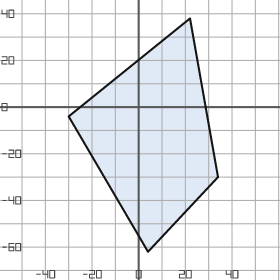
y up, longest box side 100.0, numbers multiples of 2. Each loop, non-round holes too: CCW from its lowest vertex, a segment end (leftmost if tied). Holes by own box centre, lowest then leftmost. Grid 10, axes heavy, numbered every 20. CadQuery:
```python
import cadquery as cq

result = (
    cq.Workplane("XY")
    .moveTo(4.0, -62.0)
    .lineTo(34.0, -30.0)
    .lineTo(22.0, 38.0)
    .lineTo(-30.0, -4.0)
    .close()
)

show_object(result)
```